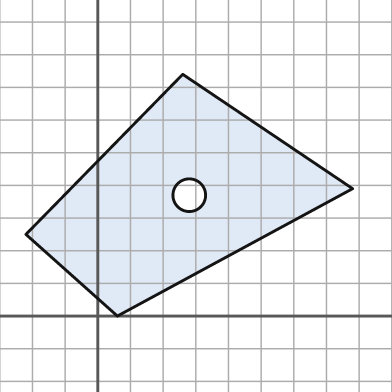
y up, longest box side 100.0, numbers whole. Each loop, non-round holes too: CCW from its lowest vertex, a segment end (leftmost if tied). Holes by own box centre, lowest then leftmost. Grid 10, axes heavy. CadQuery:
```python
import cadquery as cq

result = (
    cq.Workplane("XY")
    .moveTo(6.0, 0.0)
    .lineTo(78.0, 39.0)
    .lineTo(26.0, 74.0)
    .lineTo(-22.0, 25.0)
    .close()
    .moveTo(28.0, 37.0)
    .circle(5.0)
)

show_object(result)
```